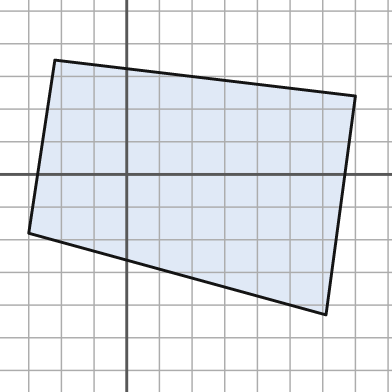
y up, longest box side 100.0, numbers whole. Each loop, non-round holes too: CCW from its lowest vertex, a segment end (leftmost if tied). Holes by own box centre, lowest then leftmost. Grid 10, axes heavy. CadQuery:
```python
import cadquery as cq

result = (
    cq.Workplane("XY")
    .moveTo(61.0, -43.0)
    .lineTo(70.0, 24.0)
    .lineTo(-22.0, 35.0)
    .lineTo(-30.0, -18.0)
    .close()
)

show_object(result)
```